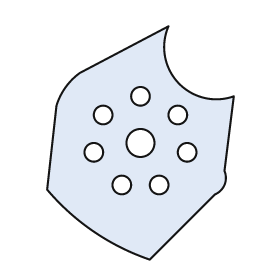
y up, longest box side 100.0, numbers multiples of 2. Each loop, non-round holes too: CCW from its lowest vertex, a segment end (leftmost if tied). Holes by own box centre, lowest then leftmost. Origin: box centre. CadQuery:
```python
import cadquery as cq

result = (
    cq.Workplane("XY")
    .moveTo(4.0, -50.0)
    .lineTo(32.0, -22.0)
    .threePointArc((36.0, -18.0), (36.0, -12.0))
    .lineTo(40.0, 20.0)
    .threePointArc((16.0, 26.0), (12.0, 50.0))
    .lineTo(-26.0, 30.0)
    .threePointArc((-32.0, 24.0), (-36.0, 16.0))
    .lineTo(-40.0, -20.0)
    .threePointArc((-20.0, -38.0), (4.0, -50.0))
    .close()
    .moveTo(-8.0, -18.0)
    .circle(4.0)
    .moveTo(8.0, -18.0)
    .circle(4.0)
    .moveTo(-20.0, -4.0)
    .circle(4.0)
    .moveTo(20.0, -4.0)
    .circle(4.0)
    .moveTo(0.0, 0.0)
    .circle(6.0)
    .moveTo(-16.0, 12.0)
    .circle(4.0)
    .moveTo(16.0, 12.0)
    .circle(4.0)
    .moveTo(0.0, 20.0)
    .circle(4.0)
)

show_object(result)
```